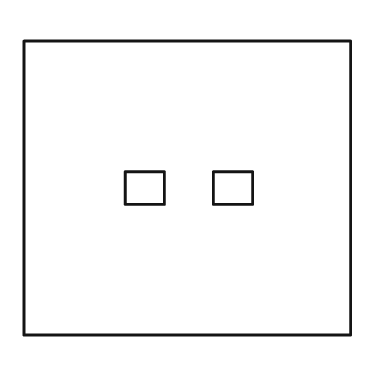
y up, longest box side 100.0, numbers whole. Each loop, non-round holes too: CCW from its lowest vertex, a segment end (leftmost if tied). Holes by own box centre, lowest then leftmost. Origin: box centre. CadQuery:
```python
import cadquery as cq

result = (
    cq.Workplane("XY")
    .moveTo(-50.0, -45.0)
    .lineTo(50.0, -45.0)
    .lineTo(50.0, 45.0)
    .lineTo(-50.0, 45.0)
    .close()
    .moveTo(-19.0, -5.0)
    .lineTo(-7.0, -5.0)
    .lineTo(-7.0, 5.0)
    .lineTo(-19.0, 5.0)
    .close()
    .moveTo(8.0, -5.0)
    .lineTo(20.0, -5.0)
    .lineTo(20.0, 5.0)
    .lineTo(8.0, 5.0)
    .close()
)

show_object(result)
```